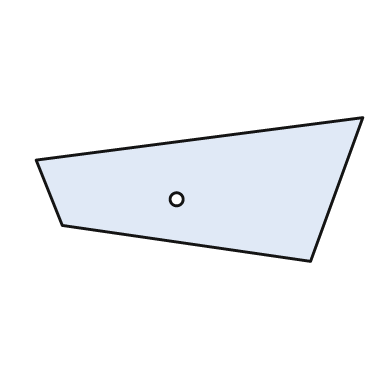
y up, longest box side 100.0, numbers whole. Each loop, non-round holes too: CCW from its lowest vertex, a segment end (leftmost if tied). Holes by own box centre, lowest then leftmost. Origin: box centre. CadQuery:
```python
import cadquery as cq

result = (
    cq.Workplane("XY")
    .moveTo(34.0, -22.0)
    .lineTo(50.0, 22.0)
    .lineTo(-50.0, 9.0)
    .lineTo(-42.0, -11.0)
    .close()
    .moveTo(-7.0, -3.0)
    .circle(2.0)
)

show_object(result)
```